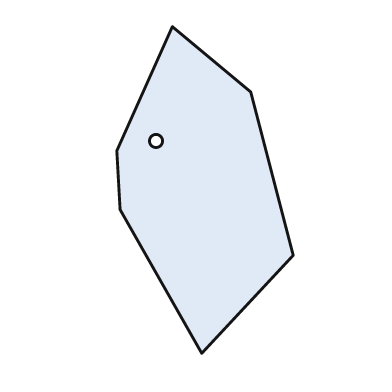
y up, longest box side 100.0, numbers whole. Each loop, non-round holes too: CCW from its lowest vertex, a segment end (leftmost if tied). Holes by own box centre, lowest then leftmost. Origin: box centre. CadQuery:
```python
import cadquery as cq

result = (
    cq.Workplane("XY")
    .moveTo(-1.0, -50.0)
    .lineTo(27.0, -20.0)
    .lineTo(14.0, 30.0)
    .lineTo(-10.0, 50.0)
    .lineTo(-27.0, 12.0)
    .lineTo(-26.0, -6.0)
    .close()
    .moveTo(-15.0, 15.0)
    .circle(2.0)
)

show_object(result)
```